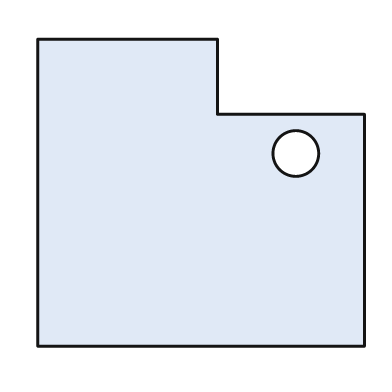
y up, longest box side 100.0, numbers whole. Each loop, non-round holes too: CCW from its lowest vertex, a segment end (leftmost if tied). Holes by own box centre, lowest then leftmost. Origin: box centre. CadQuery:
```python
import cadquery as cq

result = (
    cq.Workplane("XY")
    .moveTo(-50.0, -47.0)
    .lineTo(50.0, -47.0)
    .lineTo(50.0, 24.0)
    .lineTo(5.0, 24.0)
    .lineTo(5.0, 47.0)
    .lineTo(-50.0, 47.0)
    .close()
    .moveTo(29.0, 12.0)
    .circle(7.0)
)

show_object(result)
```